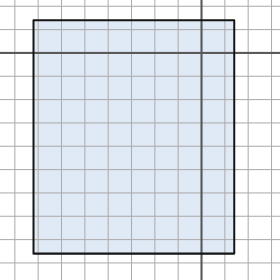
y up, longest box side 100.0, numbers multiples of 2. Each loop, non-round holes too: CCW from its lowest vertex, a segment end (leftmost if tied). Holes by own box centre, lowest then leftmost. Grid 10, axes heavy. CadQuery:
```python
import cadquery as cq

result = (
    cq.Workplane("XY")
    .moveTo(-72.0, -86.0)
    .lineTo(14.0, -86.0)
    .lineTo(14.0, 14.0)
    .lineTo(-72.0, 14.0)
    .close()
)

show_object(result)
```